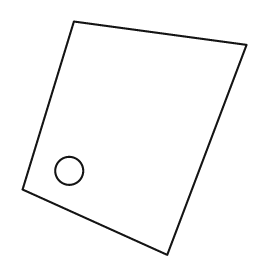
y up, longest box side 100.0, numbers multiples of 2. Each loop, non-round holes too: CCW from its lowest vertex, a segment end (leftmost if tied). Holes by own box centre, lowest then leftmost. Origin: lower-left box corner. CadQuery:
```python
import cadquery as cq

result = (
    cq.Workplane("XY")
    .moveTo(62.0, 0.0)
    .lineTo(96.0, 90.0)
    .lineTo(22.0, 100.0)
    .lineTo(0.0, 28.0)
    .close()
    .moveTo(20.0, 36.0)
    .circle(6.0)
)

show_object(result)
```